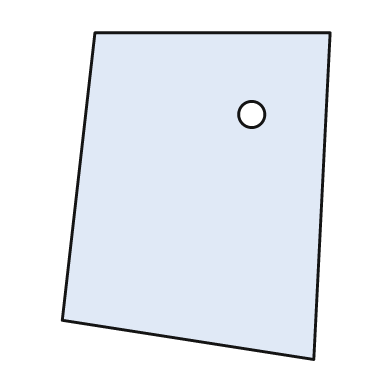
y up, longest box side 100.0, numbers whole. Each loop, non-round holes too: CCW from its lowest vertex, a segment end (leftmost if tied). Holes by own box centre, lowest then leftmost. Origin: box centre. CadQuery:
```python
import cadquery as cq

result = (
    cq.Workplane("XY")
    .moveTo(36.0, -50.0)
    .lineTo(41.0, 50.0)
    .lineTo(-31.0, 50.0)
    .lineTo(-41.0, -38.0)
    .close()
    .moveTo(17.0, 25.0)
    .circle(4.0)
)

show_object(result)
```